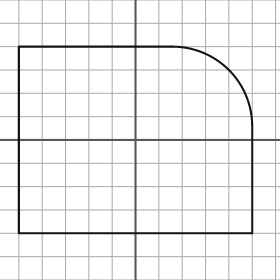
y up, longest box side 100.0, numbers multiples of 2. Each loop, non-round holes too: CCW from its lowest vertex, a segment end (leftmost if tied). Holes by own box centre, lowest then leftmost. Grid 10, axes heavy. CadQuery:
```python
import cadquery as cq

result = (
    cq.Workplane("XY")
    .moveTo(-50.0, -40.0)
    .lineTo(50.0, -40.0)
    .lineTo(50.0, 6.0)
    .threePointArc((40.0, 30.0), (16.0, 40.0))
    .lineTo(-50.0, 40.0)
    .close()
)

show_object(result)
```